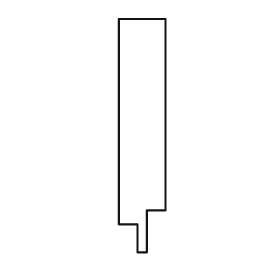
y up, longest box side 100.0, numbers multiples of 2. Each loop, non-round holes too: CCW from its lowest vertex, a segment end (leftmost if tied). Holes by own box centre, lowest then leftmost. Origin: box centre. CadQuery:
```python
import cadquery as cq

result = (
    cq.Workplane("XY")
    .moveTo(-2.0, -50.0)
    .lineTo(2.0, -50.0)
    .lineTo(2.0, -32.0)
    .lineTo(10.0, -32.0)
    .lineTo(10.0, 50.0)
    .lineTo(-10.0, 50.0)
    .lineTo(-10.0, -38.0)
    .lineTo(-2.0, -38.0)
    .close()
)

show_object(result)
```